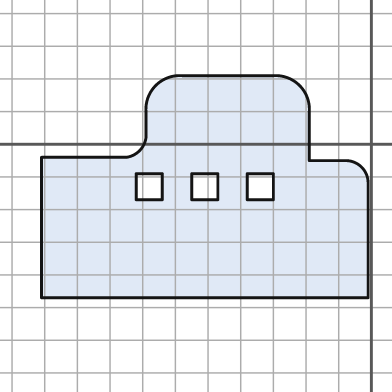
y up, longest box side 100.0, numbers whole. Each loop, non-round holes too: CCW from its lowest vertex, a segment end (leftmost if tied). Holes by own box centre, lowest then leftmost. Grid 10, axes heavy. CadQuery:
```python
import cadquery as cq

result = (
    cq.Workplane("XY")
    .moveTo(-101.0, -47.0)
    .lineTo(-1.0, -47.0)
    .lineTo(-1.0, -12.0)
    .threePointArc((-3.0, -7.0), (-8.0, -5.0))
    .lineTo(-19.0, -5.0)
    .lineTo(-19.0, 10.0)
    .threePointArc((-22.0, 18.0), (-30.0, 21.0))
    .lineTo(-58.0, 21.0)
    .threePointArc((-66.0, 18.0), (-69.0, 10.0))
    .lineTo(-69.0, 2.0)
    .threePointArc((-71.0, -2.0), (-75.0, -4.0))
    .lineTo(-101.0, -4.0)
    .close()
    .moveTo(-72.0, -17.0)
    .lineTo(-64.0, -17.0)
    .lineTo(-64.0, -9.0)
    .lineTo(-72.0, -9.0)
    .close()
    .moveTo(-55.0, -17.0)
    .lineTo(-47.0, -17.0)
    .lineTo(-47.0, -9.0)
    .lineTo(-55.0, -9.0)
    .close()
    .moveTo(-38.0, -17.0)
    .lineTo(-30.0, -17.0)
    .lineTo(-30.0, -9.0)
    .lineTo(-38.0, -9.0)
    .close()
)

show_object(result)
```